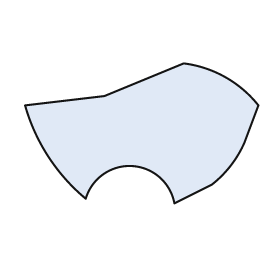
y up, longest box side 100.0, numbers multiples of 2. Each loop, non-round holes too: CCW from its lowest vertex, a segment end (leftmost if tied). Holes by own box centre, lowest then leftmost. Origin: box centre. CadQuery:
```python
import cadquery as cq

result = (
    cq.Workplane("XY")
    .moveTo(14.0, -30.0)
    .lineTo(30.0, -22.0)
    .threePointArc((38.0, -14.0), (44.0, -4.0))
    .lineTo(50.0, 12.0)
    .threePointArc((36.0, 24.0), (18.0, 30.0))
    .lineTo(-16.0, 16.0)
    .lineTo(-50.0, 12.0)
    .threePointArc((-40.0, -10.0), (-24.0, -28.0))
    .threePointArc((-4.0, -14.0), (14.0, -30.0))
    .close()
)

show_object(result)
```